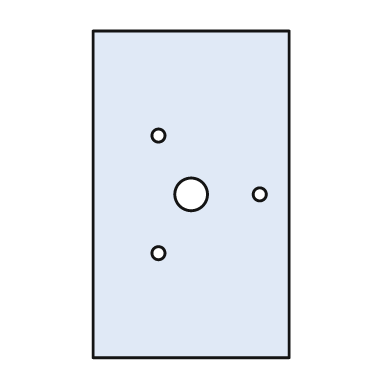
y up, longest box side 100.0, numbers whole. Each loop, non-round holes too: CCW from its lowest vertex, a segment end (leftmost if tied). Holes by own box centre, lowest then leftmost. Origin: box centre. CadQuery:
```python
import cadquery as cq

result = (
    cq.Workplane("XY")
    .moveTo(-30.0, -50.0)
    .lineTo(30.0, -50.0)
    .lineTo(30.0, 50.0)
    .lineTo(-30.0, 50.0)
    .close()
    .moveTo(-10.0, -18.0)
    .circle(2.0)
    .moveTo(0.0, 0.0)
    .circle(5.0)
    .moveTo(21.0, 0.0)
    .circle(2.0)
    .moveTo(-10.0, 18.0)
    .circle(2.0)
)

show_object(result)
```